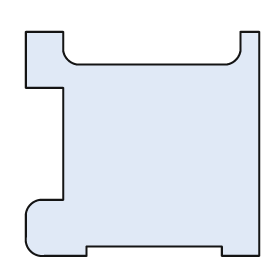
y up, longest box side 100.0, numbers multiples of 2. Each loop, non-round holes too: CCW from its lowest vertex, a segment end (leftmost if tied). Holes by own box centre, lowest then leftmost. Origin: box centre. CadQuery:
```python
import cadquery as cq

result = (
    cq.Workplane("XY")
    .moveTo(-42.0, -48.0)
    .lineTo(-24.0, -48.0)
    .lineTo(-24.0, -44.0)
    .lineTo(34.0, -44.0)
    .lineTo(34.0, -48.0)
    .lineTo(50.0, -48.0)
    .lineTo(50.0, 48.0)
    .lineTo(42.0, 48.0)
    .lineTo(42.0, 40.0)
    .threePointArc((40.0, 36.0), (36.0, 34.0))
    .lineTo(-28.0, 34.0)
    .threePointArc((-32.0, 36.0), (-34.0, 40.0))
    .lineTo(-34.0, 48.0)
    .lineTo(-50.0, 48.0)
    .lineTo(-50.0, 24.0)
    .lineTo(-34.0, 24.0)
    .lineTo(-34.0, -24.0)
    .lineTo(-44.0, -24.0)
    .threePointArc((-48.0, -26.0), (-50.0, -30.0))
    .lineTo(-50.0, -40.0)
    .threePointArc((-48.0, -46.0), (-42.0, -48.0))
    .close()
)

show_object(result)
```